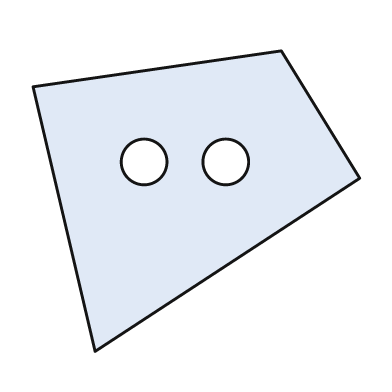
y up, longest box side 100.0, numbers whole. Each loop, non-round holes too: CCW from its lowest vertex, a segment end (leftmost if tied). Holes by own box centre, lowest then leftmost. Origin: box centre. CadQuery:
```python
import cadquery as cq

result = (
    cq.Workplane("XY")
    .moveTo(-31.0, -46.0)
    .lineTo(50.0, 7.0)
    .lineTo(26.0, 46.0)
    .lineTo(-50.0, 35.0)
    .close()
    .moveTo(-16.0, 12.0)
    .circle(7.0)
    .moveTo(9.0, 12.0)
    .circle(7.0)
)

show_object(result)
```